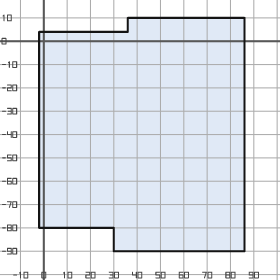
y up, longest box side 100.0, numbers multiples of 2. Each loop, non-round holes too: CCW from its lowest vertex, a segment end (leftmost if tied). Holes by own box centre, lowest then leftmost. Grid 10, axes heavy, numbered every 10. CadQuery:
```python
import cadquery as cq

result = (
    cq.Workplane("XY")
    .moveTo(30.0, -90.0)
    .lineTo(86.0, -90.0)
    .lineTo(86.0, 10.0)
    .lineTo(36.0, 10.0)
    .lineTo(36.0, 4.0)
    .lineTo(-2.0, 4.0)
    .lineTo(-2.0, -80.0)
    .lineTo(30.0, -80.0)
    .close()
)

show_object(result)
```